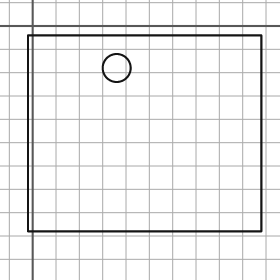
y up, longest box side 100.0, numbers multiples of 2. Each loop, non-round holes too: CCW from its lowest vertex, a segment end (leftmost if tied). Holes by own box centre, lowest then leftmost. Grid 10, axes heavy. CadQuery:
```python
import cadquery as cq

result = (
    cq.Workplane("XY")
    .moveTo(-2.0, -88.0)
    .lineTo(98.0, -88.0)
    .lineTo(98.0, -4.0)
    .lineTo(-2.0, -4.0)
    .close()
    .moveTo(36.0, -18.0)
    .circle(6.0)
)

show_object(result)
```